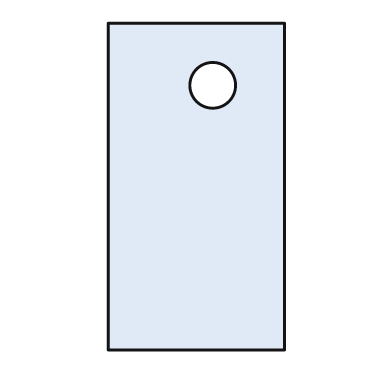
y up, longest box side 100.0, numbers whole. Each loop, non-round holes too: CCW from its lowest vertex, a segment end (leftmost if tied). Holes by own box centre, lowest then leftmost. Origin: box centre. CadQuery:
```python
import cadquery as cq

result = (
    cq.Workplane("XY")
    .moveTo(-27.0, -50.0)
    .lineTo(27.0, -50.0)
    .lineTo(27.0, 50.0)
    .lineTo(-27.0, 50.0)
    .close()
    .moveTo(5.0, 31.0)
    .circle(7.0)
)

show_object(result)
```